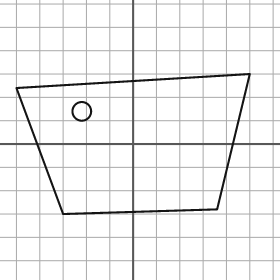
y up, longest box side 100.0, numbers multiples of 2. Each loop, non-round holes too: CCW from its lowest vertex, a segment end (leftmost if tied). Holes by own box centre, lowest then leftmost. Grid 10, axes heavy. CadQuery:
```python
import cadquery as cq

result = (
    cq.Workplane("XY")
    .moveTo(-30.0, -30.0)
    .lineTo(36.0, -28.0)
    .lineTo(50.0, 30.0)
    .lineTo(-50.0, 24.0)
    .close()
    .moveTo(-22.0, 14.0)
    .circle(4.0)
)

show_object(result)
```